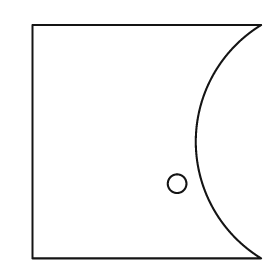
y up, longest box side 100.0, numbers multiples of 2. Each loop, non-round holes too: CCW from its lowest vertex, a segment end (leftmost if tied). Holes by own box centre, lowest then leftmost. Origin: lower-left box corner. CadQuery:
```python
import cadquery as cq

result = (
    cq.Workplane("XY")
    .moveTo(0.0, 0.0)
    .lineTo(98.0, 0.0)
    .threePointArc((70.0, 50.0), (98.0, 100.0))
    .lineTo(0.0, 100.0)
    .close()
    .moveTo(62.0, 32.0)
    .circle(4.0)
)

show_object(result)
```